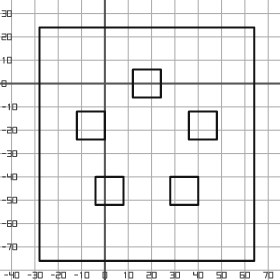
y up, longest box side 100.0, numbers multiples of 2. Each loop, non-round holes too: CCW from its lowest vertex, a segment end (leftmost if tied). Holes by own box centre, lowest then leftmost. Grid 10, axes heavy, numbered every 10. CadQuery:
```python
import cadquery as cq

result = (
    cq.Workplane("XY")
    .moveTo(-28.0, -76.0)
    .lineTo(64.0, -76.0)
    .lineTo(64.0, 24.0)
    .lineTo(-28.0, 24.0)
    .close()
    .moveTo(-4.0, -52.0)
    .lineTo(8.0, -52.0)
    .lineTo(8.0, -40.0)
    .lineTo(-4.0, -40.0)
    .close()
    .moveTo(28.0, -52.0)
    .lineTo(40.0, -52.0)
    .lineTo(40.0, -40.0)
    .lineTo(28.0, -40.0)
    .close()
    .moveTo(-12.0, -24.0)
    .lineTo(0.0, -24.0)
    .lineTo(0.0, -12.0)
    .lineTo(-12.0, -12.0)
    .close()
    .moveTo(36.0, -24.0)
    .lineTo(48.0, -24.0)
    .lineTo(48.0, -12.0)
    .lineTo(36.0, -12.0)
    .close()
    .moveTo(12.0, -6.0)
    .lineTo(24.0, -6.0)
    .lineTo(24.0, 6.0)
    .lineTo(12.0, 6.0)
    .close()
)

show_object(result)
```